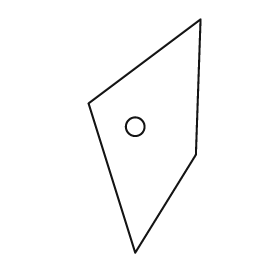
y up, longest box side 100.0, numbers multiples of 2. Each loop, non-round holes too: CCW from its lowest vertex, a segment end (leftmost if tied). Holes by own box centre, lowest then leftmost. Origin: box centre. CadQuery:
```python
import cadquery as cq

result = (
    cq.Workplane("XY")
    .moveTo(-4.0, -50.0)
    .lineTo(22.0, -8.0)
    .lineTo(24.0, 50.0)
    .lineTo(-24.0, 14.0)
    .close()
    .moveTo(-4.0, 4.0)
    .circle(4.0)
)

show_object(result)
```